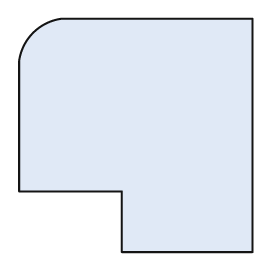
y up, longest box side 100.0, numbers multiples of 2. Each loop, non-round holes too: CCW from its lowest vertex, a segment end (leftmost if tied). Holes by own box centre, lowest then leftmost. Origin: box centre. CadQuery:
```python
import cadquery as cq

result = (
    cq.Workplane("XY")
    .moveTo(-6.0, -50.0)
    .lineTo(50.0, -50.0)
    .lineTo(50.0, 50.0)
    .lineTo(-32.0, 50.0)
    .threePointArc((-44.0, 44.0), (-50.0, 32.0))
    .lineTo(-50.0, -24.0)
    .lineTo(-6.0, -24.0)
    .close()
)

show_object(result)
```